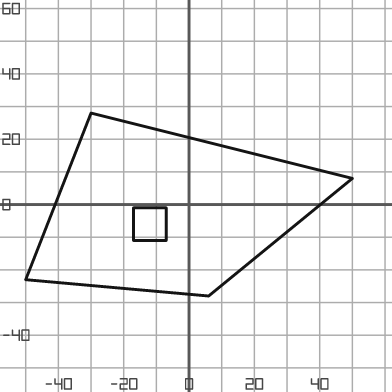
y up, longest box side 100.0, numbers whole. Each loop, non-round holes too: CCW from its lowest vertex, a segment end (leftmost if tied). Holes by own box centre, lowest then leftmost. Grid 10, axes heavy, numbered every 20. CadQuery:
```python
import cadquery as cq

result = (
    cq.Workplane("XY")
    .moveTo(6.0, -28.0)
    .lineTo(50.0, 8.0)
    .lineTo(-30.0, 28.0)
    .lineTo(-50.0, -23.0)
    .close()
    .moveTo(-17.0, -11.0)
    .lineTo(-7.0, -11.0)
    .lineTo(-7.0, -1.0)
    .lineTo(-17.0, -1.0)
    .close()
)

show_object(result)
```